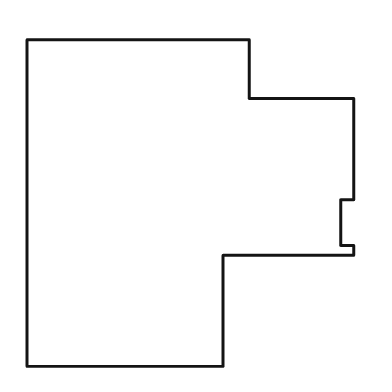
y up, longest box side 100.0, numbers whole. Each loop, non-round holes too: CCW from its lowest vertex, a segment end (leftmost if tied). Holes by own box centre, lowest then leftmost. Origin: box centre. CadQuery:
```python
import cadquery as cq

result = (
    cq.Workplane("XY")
    .moveTo(-50.0, -50.0)
    .lineTo(10.0, -50.0)
    .lineTo(10.0, -16.0)
    .lineTo(50.0, -16.0)
    .lineTo(50.0, -13.0)
    .lineTo(46.0, -13.0)
    .lineTo(46.0, 1.0)
    .lineTo(50.0, 1.0)
    .lineTo(50.0, 32.0)
    .lineTo(18.0, 32.0)
    .lineTo(18.0, 50.0)
    .lineTo(-50.0, 50.0)
    .close()
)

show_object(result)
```